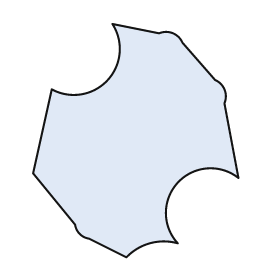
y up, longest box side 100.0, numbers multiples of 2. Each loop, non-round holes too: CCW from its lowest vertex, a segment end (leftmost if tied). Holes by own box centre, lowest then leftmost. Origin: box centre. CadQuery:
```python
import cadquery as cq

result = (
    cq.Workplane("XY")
    .moveTo(-4.0, -50.0)
    .threePointArc((6.0, -44.0), (18.0, -44.0))
    .threePointArc((18.0, -18.0), (44.0, -16.0))
    .lineTo(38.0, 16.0)
    .threePointArc((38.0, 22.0), (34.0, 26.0))
    .lineTo(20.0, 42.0)
    .threePointArc((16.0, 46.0), (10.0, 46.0))
    .lineTo(-10.0, 50.0)
    .threePointArc((-12.0, 26.0), (-36.0, 22.0))
    .lineTo(-44.0, -14.0)
    .lineTo(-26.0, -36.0)
    .threePointArc((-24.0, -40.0), (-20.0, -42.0))
    .close()
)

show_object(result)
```